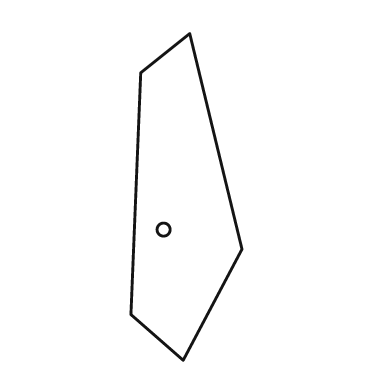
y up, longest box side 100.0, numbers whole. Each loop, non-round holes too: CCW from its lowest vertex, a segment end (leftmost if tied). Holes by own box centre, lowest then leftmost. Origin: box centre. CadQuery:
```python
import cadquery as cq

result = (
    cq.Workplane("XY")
    .moveTo(-1.0, -50.0)
    .lineTo(17.0, -16.0)
    .lineTo(1.0, 50.0)
    .lineTo(-14.0, 38.0)
    .lineTo(-17.0, -36.0)
    .close()
    .moveTo(-7.0, -10.0)
    .circle(2.0)
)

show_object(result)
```